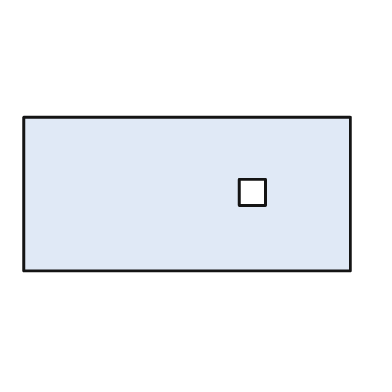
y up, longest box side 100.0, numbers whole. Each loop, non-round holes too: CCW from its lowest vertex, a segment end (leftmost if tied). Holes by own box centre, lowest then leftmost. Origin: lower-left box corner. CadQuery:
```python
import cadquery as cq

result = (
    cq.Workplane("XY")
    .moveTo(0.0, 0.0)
    .lineTo(100.0, 0.0)
    .lineTo(100.0, 47.0)
    .lineTo(0.0, 47.0)
    .close()
    .moveTo(66.0, 20.0)
    .lineTo(74.0, 20.0)
    .lineTo(74.0, 28.0)
    .lineTo(66.0, 28.0)
    .close()
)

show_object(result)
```